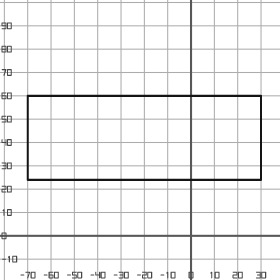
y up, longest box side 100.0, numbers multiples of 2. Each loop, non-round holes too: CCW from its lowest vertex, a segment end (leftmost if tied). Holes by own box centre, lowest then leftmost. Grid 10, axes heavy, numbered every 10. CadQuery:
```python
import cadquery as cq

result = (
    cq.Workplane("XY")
    .moveTo(-70.0, 24.0)
    .lineTo(30.0, 24.0)
    .lineTo(30.0, 60.0)
    .lineTo(-70.0, 60.0)
    .close()
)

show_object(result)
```